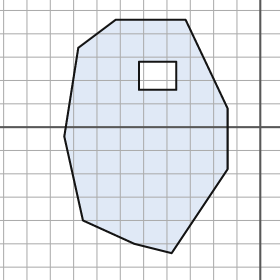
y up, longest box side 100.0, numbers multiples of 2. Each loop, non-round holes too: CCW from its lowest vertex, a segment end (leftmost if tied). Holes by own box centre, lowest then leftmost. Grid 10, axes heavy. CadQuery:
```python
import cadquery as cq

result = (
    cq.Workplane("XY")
    .moveTo(-38.0, -54.0)
    .lineTo(-14.0, -18.0)
    .lineTo(-14.0, 8.0)
    .lineTo(-32.0, 46.0)
    .lineTo(-62.0, 46.0)
    .lineTo(-78.0, 34.0)
    .lineTo(-84.0, -4.0)
    .lineTo(-76.0, -40.0)
    .lineTo(-54.0, -50.0)
    .close()
    .moveTo(-52.0, 16.0)
    .lineTo(-36.0, 16.0)
    .lineTo(-36.0, 28.0)
    .lineTo(-52.0, 28.0)
    .close()
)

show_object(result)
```